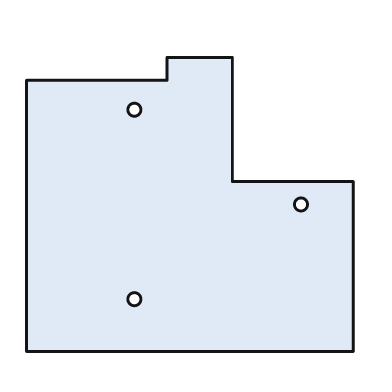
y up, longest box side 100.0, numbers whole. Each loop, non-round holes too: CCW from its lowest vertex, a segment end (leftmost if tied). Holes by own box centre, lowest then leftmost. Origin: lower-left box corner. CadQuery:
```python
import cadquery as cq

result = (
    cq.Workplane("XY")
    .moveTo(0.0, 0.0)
    .lineTo(100.0, 0.0)
    .lineTo(100.0, 52.0)
    .lineTo(63.0, 52.0)
    .lineTo(63.0, 90.0)
    .lineTo(43.0, 90.0)
    .lineTo(43.0, 83.0)
    .lineTo(0.0, 83.0)
    .close()
    .moveTo(33.0, 16.0)
    .circle(2.0)
    .moveTo(84.0, 45.0)
    .circle(2.0)
    .moveTo(33.0, 74.0)
    .circle(2.0)
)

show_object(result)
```